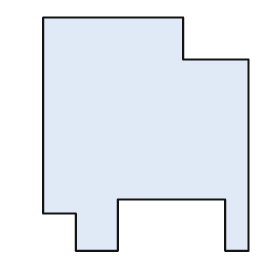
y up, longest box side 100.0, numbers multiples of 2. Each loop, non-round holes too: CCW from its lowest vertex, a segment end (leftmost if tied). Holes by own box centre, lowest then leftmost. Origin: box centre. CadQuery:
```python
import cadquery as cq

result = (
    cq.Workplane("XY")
    .moveTo(-30.0, -50.0)
    .lineTo(-12.0, -50.0)
    .lineTo(-12.0, -28.0)
    .lineTo(34.0, -28.0)
    .lineTo(34.0, -50.0)
    .lineTo(44.0, -50.0)
    .lineTo(44.0, 32.0)
    .lineTo(16.0, 32.0)
    .lineTo(16.0, 50.0)
    .lineTo(-44.0, 50.0)
    .lineTo(-44.0, -34.0)
    .lineTo(-30.0, -34.0)
    .close()
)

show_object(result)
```